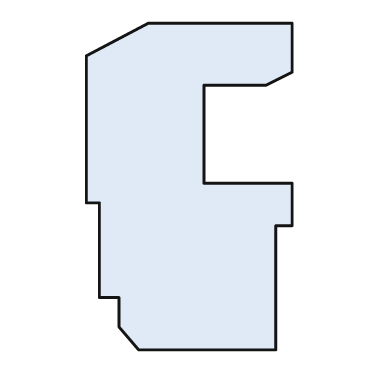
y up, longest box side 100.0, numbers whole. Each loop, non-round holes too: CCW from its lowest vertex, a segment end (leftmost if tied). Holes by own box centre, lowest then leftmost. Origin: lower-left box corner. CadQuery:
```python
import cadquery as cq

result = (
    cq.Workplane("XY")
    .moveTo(16.0, 0.0)
    .lineTo(58.0, 0.0)
    .lineTo(58.0, 38.0)
    .lineTo(63.0, 38.0)
    .lineTo(63.0, 51.0)
    .lineTo(36.0, 51.0)
    .lineTo(36.0, 81.0)
    .lineTo(55.0, 81.0)
    .lineTo(63.0, 85.0)
    .lineTo(63.0, 100.0)
    .lineTo(19.0, 100.0)
    .lineTo(0.0, 90.0)
    .lineTo(0.0, 45.0)
    .lineTo(4.0, 45.0)
    .lineTo(4.0, 16.0)
    .lineTo(10.0, 16.0)
    .lineTo(10.0, 7.0)
    .close()
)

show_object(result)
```